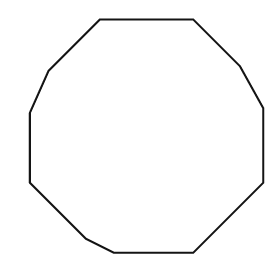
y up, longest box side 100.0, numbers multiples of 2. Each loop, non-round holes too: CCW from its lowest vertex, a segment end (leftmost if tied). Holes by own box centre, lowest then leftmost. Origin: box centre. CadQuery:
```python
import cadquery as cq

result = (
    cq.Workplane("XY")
    .moveTo(-14.0, -50.0)
    .lineTo(20.0, -50.0)
    .lineTo(50.0, -20.0)
    .lineTo(50.0, 12.0)
    .lineTo(40.0, 30.0)
    .lineTo(20.0, 50.0)
    .lineTo(-20.0, 50.0)
    .lineTo(-42.0, 28.0)
    .lineTo(-50.0, 10.0)
    .lineTo(-50.0, -20.0)
    .lineTo(-26.0, -44.0)
    .close()
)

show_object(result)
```